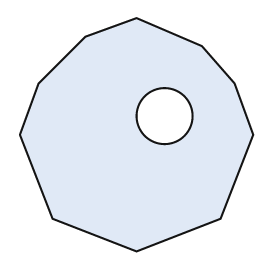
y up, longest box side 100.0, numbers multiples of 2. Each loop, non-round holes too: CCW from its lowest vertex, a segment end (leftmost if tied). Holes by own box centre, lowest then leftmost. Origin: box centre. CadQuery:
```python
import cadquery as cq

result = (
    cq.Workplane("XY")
    .moveTo(0.0, -50.0)
    .lineTo(36.0, -36.0)
    .lineTo(50.0, 0.0)
    .lineTo(42.0, 22.0)
    .lineTo(28.0, 38.0)
    .lineTo(0.0, 50.0)
    .lineTo(-22.0, 42.0)
    .lineTo(-42.0, 22.0)
    .lineTo(-50.0, 0.0)
    .lineTo(-36.0, -36.0)
    .close()
    .moveTo(12.0, 8.0)
    .circle(12.0)
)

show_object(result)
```